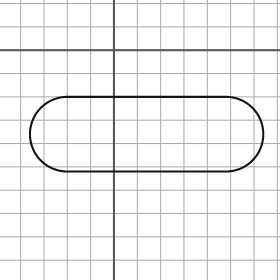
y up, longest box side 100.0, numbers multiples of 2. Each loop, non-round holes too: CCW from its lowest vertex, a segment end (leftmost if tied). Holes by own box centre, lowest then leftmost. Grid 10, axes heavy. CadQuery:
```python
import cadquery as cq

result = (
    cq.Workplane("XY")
    .moveTo(-20.0, -52.0)
    .lineTo(48.0, -52.0)
    .threePointArc((64.0, -36.0), (48.0, -20.0))
    .lineTo(-20.0, -20.0)
    .threePointArc((-36.0, -36.0), (-20.0, -52.0))
    .close()
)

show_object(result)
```